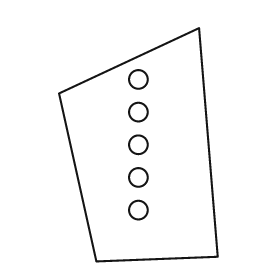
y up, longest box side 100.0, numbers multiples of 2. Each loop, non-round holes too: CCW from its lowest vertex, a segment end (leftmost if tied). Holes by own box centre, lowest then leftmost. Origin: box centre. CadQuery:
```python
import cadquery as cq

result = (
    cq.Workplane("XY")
    .moveTo(-18.0, -50.0)
    .lineTo(34.0, -48.0)
    .lineTo(26.0, 50.0)
    .lineTo(-34.0, 22.0)
    .close()
    .moveTo(0.0, -28.0)
    .circle(4.0)
    .moveTo(0.0, -14.0)
    .circle(4.0)
    .moveTo(0.0, 0.0)
    .circle(4.0)
    .moveTo(0.0, 14.0)
    .circle(4.0)
    .moveTo(0.0, 28.0)
    .circle(4.0)
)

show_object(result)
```